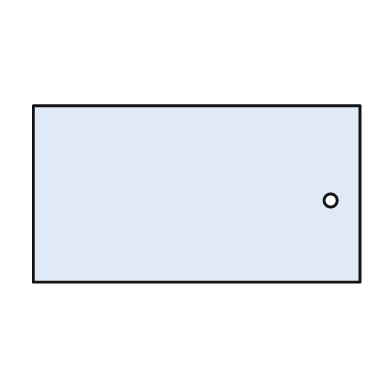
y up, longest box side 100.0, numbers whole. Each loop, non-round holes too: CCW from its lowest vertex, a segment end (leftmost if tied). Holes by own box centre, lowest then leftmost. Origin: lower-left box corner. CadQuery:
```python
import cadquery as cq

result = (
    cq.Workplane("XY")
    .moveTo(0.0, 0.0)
    .lineTo(100.0, 0.0)
    .lineTo(100.0, 54.0)
    .lineTo(0.0, 54.0)
    .close()
    .moveTo(91.0, 25.0)
    .circle(2.0)
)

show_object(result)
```